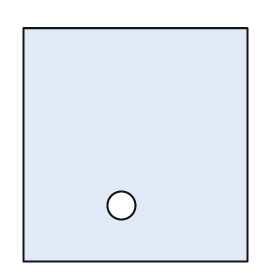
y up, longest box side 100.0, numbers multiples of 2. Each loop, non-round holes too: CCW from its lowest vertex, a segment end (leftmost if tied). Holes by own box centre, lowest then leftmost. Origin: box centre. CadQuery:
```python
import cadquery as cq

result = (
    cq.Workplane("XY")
    .moveTo(-48.0, -50.0)
    .lineTo(48.0, -50.0)
    .lineTo(48.0, 50.0)
    .lineTo(-48.0, 50.0)
    .close()
    .moveTo(-6.0, -26.0)
    .circle(6.0)
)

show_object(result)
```